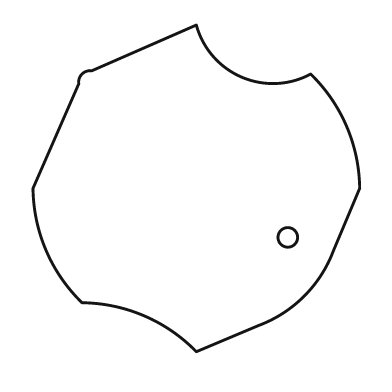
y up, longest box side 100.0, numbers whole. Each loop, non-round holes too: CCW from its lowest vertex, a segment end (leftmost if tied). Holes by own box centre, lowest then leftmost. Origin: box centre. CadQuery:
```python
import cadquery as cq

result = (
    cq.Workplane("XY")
    .moveTo(0.0, -50.0)
    .lineTo(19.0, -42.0)
    .threePointArc((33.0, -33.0), (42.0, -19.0))
    .lineTo(50.0, 0.0)
    .threePointArc((46.0, 19.0), (35.0, 35.0))
    .threePointArc((14.0, 34.0), (0.0, 50.0))
    .lineTo(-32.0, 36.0)
    .threePointArc((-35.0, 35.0), (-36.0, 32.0))
    .lineTo(-50.0, 0.0)
    .threePointArc((-46.0, -19.0), (-35.0, -35.0))
    .threePointArc((-16.0, -39.0), (0.0, -50.0))
    .close()
    .moveTo(28.0, -15.0)
    .circle(3.0)
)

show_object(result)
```